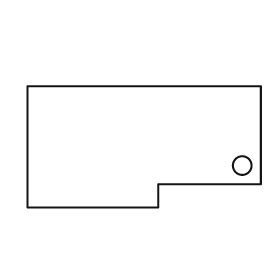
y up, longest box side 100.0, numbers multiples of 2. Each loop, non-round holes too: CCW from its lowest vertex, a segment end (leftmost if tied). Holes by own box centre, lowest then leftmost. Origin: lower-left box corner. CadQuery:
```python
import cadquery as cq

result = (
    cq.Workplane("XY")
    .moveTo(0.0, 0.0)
    .lineTo(56.0, 0.0)
    .lineTo(56.0, 10.0)
    .lineTo(100.0, 10.0)
    .lineTo(100.0, 52.0)
    .lineTo(0.0, 52.0)
    .close()
    .moveTo(92.0, 18.0)
    .circle(4.0)
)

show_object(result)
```